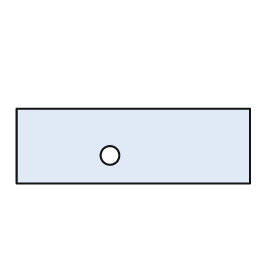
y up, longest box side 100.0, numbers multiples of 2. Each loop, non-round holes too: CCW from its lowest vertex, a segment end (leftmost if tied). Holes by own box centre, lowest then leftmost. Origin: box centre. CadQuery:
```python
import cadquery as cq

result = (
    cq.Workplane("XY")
    .moveTo(-50.0, -16.0)
    .lineTo(50.0, -16.0)
    .lineTo(50.0, 16.0)
    .lineTo(-50.0, 16.0)
    .close()
    .moveTo(-10.0, -4.0)
    .circle(4.0)
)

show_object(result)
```